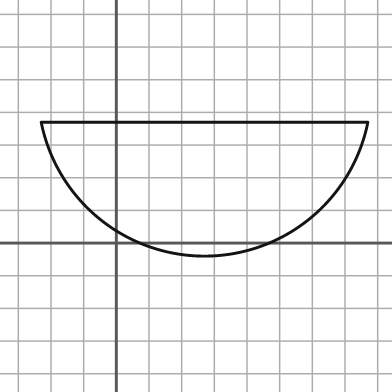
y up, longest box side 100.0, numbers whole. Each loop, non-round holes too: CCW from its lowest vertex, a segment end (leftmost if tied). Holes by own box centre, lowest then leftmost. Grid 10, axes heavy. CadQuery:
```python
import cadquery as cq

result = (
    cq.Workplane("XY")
    .moveTo(-23.0, 37.0)
    .threePointArc((27.0, -4.0), (77.0, 37.0))
    .close()
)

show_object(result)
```